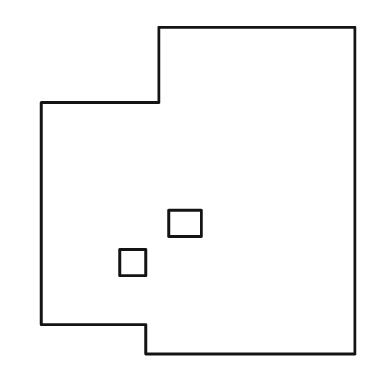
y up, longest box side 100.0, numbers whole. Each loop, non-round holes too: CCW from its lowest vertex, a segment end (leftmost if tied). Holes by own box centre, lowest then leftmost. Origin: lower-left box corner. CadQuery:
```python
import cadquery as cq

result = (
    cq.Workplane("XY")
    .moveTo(32.0, 0.0)
    .lineTo(96.0, 0.0)
    .lineTo(96.0, 100.0)
    .lineTo(36.0, 100.0)
    .lineTo(36.0, 77.0)
    .lineTo(0.0, 77.0)
    .lineTo(0.0, 9.0)
    .lineTo(32.0, 9.0)
    .close()
    .moveTo(24.0, 24.0)
    .lineTo(32.0, 24.0)
    .lineTo(32.0, 32.0)
    .lineTo(24.0, 32.0)
    .close()
    .moveTo(39.0, 36.0)
    .lineTo(49.0, 36.0)
    .lineTo(49.0, 44.0)
    .lineTo(39.0, 44.0)
    .close()
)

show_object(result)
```